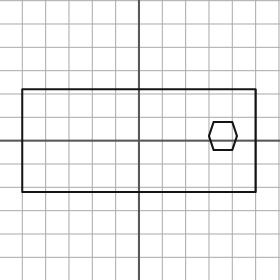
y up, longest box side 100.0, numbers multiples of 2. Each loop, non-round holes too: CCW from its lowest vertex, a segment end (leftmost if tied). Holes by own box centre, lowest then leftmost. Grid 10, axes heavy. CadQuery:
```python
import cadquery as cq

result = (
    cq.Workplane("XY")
    .moveTo(-50.0, -22.0)
    .lineTo(50.0, -22.0)
    .lineTo(50.0, 22.0)
    .lineTo(-50.0, 22.0)
    .close()
    .moveTo(32.0, -4.0)
    .lineTo(40.0, -4.0)
    .lineTo(42.0, 2.0)
    .lineTo(40.0, 8.0)
    .lineTo(32.0, 8.0)
    .lineTo(30.0, 2.0)
    .close()
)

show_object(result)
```